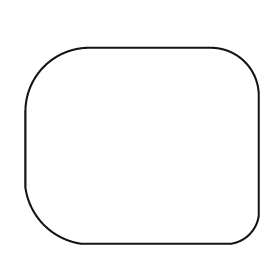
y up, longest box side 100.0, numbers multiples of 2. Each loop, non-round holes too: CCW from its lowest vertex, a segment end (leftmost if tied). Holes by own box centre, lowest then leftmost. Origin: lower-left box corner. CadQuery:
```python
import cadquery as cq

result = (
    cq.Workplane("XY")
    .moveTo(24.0, 0.0)
    .lineTo(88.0, 0.0)
    .threePointArc((96.0, 4.0), (100.0, 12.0))
    .lineTo(100.0, 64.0)
    .threePointArc((94.0, 78.0), (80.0, 84.0))
    .lineTo(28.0, 84.0)
    .threePointArc((8.0, 76.0), (0.0, 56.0))
    .lineTo(0.0, 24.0)
    .threePointArc((8.0, 8.0), (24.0, 0.0))
    .close()
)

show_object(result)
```